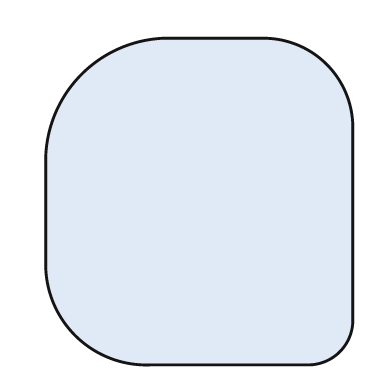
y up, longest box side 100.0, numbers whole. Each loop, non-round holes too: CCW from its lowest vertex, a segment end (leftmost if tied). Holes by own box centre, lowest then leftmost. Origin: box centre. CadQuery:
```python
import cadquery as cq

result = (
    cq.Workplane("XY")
    .moveTo(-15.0, -50.0)
    .lineTo(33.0, -50.0)
    .threePointArc((43.0, -46.0), (47.0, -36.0))
    .lineTo(47.0, 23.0)
    .threePointArc((39.0, 42.0), (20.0, 50.0))
    .lineTo(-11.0, 50.0)
    .threePointArc((-36.0, 39.0), (-47.0, 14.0))
    .lineTo(-47.0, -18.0)
    .threePointArc((-38.0, -41.0), (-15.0, -50.0))
    .close()
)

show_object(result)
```